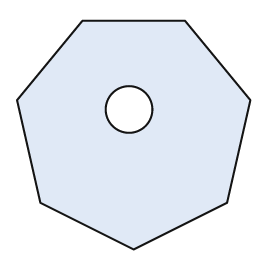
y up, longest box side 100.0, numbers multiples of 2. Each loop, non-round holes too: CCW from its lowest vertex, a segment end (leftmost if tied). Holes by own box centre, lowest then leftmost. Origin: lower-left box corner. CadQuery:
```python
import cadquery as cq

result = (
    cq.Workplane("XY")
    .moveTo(50.0, 0.0)
    .lineTo(90.0, 20.0)
    .lineTo(100.0, 64.0)
    .lineTo(72.0, 98.0)
    .lineTo(28.0, 98.0)
    .lineTo(0.0, 64.0)
    .lineTo(10.0, 20.0)
    .close()
    .moveTo(48.0, 60.0)
    .circle(10.0)
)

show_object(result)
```